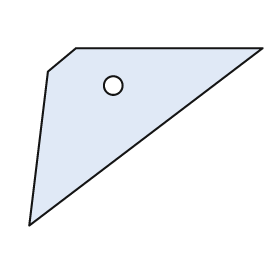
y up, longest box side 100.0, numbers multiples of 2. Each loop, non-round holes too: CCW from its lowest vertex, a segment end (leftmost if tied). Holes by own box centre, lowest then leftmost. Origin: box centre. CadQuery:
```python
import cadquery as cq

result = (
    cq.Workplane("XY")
    .moveTo(-50.0, -38.0)
    .lineTo(50.0, 38.0)
    .lineTo(-30.0, 38.0)
    .lineTo(-42.0, 28.0)
    .close()
    .moveTo(-14.0, 22.0)
    .circle(4.0)
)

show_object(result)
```